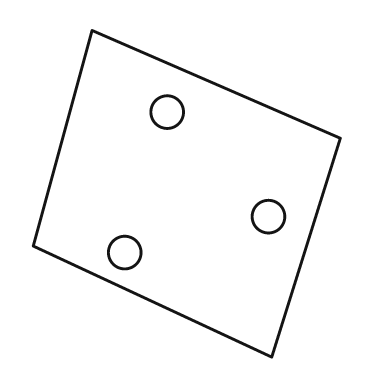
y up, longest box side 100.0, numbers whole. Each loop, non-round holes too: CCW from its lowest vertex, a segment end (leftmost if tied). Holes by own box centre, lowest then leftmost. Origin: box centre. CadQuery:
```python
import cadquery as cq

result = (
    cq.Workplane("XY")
    .moveTo(26.0, -50.0)
    .lineTo(47.0, 17.0)
    .lineTo(-29.0, 50.0)
    .lineTo(-47.0, -16.0)
    .close()
    .moveTo(-19.0, -18.0)
    .circle(5.0)
    .moveTo(25.0, -7.0)
    .circle(5.0)
    .moveTo(-6.0, 25.0)
    .circle(5.0)
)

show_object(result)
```